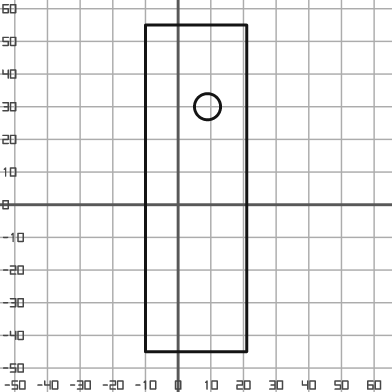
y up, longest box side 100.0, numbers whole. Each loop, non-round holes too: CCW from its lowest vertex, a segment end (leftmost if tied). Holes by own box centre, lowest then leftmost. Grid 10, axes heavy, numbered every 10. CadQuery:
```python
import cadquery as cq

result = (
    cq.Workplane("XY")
    .moveTo(-10.0, -45.0)
    .lineTo(21.0, -45.0)
    .lineTo(21.0, 55.0)
    .lineTo(-10.0, 55.0)
    .close()
    .moveTo(9.0, 30.0)
    .circle(4.0)
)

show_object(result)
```